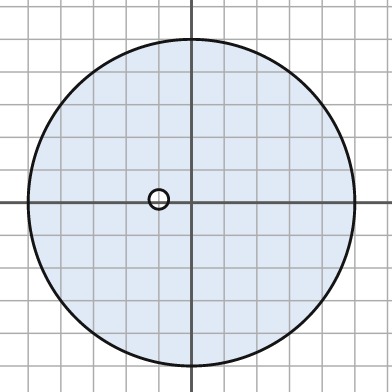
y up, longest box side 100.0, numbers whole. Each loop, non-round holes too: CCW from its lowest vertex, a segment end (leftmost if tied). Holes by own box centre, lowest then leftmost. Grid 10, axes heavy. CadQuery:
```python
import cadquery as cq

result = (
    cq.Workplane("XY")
    .moveTo(0.0, 0.0)
    .circle(50.0)
    .moveTo(-10.0, 1.0)
    .circle(3.0)
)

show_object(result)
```